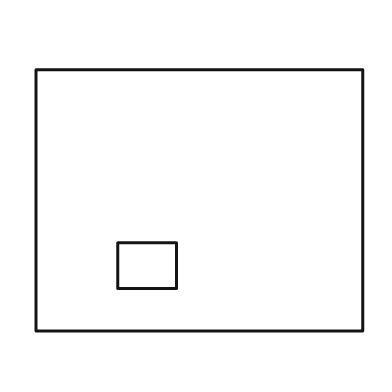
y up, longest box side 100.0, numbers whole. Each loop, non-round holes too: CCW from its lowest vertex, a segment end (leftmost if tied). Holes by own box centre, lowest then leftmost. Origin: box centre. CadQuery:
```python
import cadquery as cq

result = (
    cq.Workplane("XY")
    .moveTo(-50.0, -40.0)
    .lineTo(50.0, -40.0)
    .lineTo(50.0, 40.0)
    .lineTo(-50.0, 40.0)
    .close()
    .moveTo(-25.0, -27.0)
    .lineTo(-7.0, -27.0)
    .lineTo(-7.0, -13.0)
    .lineTo(-25.0, -13.0)
    .close()
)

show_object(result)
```